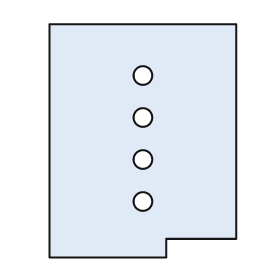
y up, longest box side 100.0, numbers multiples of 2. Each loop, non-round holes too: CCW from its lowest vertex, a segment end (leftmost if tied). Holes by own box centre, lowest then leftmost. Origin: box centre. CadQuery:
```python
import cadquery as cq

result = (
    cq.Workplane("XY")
    .moveTo(-40.0, -50.0)
    .lineTo(10.0, -50.0)
    .lineTo(10.0, -42.0)
    .lineTo(40.0, -42.0)
    .lineTo(40.0, 50.0)
    .lineTo(-40.0, 50.0)
    .close()
    .moveTo(0.0, -26.0)
    .circle(4.0)
    .moveTo(0.0, -8.0)
    .circle(4.0)
    .moveTo(0.0, 10.0)
    .circle(4.0)
    .moveTo(0.0, 28.0)
    .circle(4.0)
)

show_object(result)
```